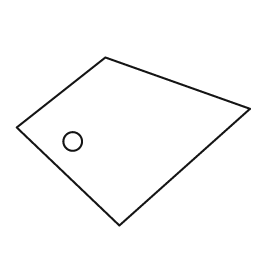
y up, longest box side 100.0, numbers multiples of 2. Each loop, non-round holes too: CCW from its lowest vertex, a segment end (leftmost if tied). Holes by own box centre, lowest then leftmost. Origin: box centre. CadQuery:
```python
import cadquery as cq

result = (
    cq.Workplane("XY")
    .moveTo(-6.0, -36.0)
    .lineTo(50.0, 14.0)
    .lineTo(-12.0, 36.0)
    .lineTo(-50.0, 6.0)
    .close()
    .moveTo(-26.0, 0.0)
    .circle(4.0)
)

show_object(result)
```